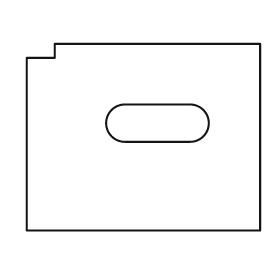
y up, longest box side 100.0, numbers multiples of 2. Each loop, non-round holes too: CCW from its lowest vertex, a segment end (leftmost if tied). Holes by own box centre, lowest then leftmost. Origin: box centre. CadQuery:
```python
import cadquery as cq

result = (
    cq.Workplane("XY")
    .moveTo(-50.0, -40.0)
    .lineTo(50.0, -40.0)
    .lineTo(50.0, 40.0)
    .lineTo(-38.0, 40.0)
    .lineTo(-38.0, 34.0)
    .lineTo(-50.0, 34.0)
    .close()
    .moveTo(-8.0, -2.0)
    .lineTo(20.0, -2.0)
    .threePointArc((28.0, 6.0), (20.0, 14.0))
    .lineTo(-8.0, 14.0)
    .threePointArc((-16.0, 6.0), (-8.0, -2.0))
    .close()
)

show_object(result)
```